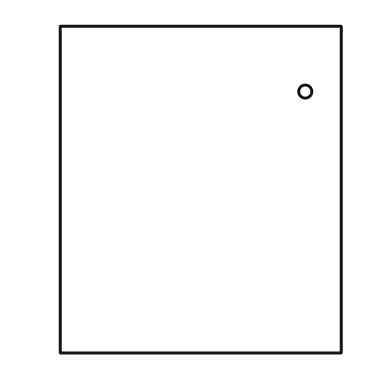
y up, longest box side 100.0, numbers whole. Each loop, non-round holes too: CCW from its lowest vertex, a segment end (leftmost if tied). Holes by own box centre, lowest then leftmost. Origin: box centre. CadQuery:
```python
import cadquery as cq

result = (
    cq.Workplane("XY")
    .moveTo(-43.0, -50.0)
    .lineTo(43.0, -50.0)
    .lineTo(43.0, 50.0)
    .lineTo(-43.0, 50.0)
    .close()
    .moveTo(32.0, 30.0)
    .circle(2.0)
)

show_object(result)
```